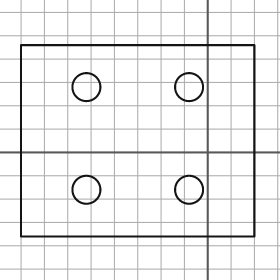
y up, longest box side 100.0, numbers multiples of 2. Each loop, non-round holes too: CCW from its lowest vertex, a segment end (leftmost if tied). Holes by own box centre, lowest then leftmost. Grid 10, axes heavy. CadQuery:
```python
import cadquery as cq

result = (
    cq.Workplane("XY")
    .moveTo(-80.0, -36.0)
    .lineTo(20.0, -36.0)
    .lineTo(20.0, 46.0)
    .lineTo(-80.0, 46.0)
    .close()
    .moveTo(-52.0, -16.0)
    .circle(6.0)
    .moveTo(-8.0, -16.0)
    .circle(6.0)
    .moveTo(-52.0, 28.0)
    .circle(6.0)
    .moveTo(-8.0, 28.0)
    .circle(6.0)
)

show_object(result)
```